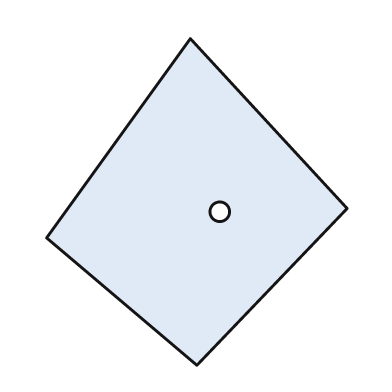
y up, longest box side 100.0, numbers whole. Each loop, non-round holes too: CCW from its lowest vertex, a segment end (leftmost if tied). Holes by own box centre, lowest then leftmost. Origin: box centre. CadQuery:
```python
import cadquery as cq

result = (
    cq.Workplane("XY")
    .moveTo(0.0, -50.0)
    .lineTo(46.0, -2.0)
    .lineTo(-2.0, 50.0)
    .lineTo(-46.0, -11.0)
    .close()
    .moveTo(7.0, -3.0)
    .circle(3.0)
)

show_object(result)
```